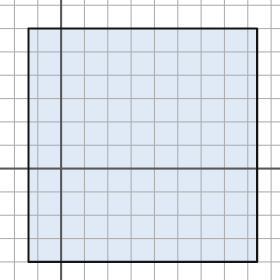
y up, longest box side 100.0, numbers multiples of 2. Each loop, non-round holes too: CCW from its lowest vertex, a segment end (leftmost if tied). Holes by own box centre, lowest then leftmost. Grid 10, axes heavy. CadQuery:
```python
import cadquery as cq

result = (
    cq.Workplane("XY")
    .moveTo(-14.0, -40.0)
    .lineTo(84.0, -40.0)
    .lineTo(84.0, 60.0)
    .lineTo(-14.0, 60.0)
    .close()
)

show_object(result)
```